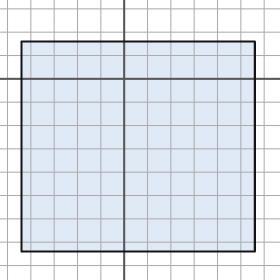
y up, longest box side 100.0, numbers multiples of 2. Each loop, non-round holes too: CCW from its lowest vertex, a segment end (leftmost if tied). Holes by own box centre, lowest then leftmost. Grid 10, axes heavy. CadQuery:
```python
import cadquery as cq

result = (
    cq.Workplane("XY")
    .moveTo(-44.0, -74.0)
    .lineTo(56.0, -74.0)
    .lineTo(56.0, 16.0)
    .lineTo(-44.0, 16.0)
    .close()
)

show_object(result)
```